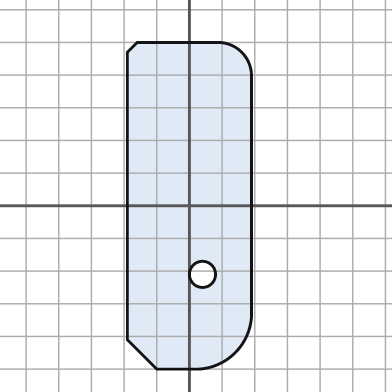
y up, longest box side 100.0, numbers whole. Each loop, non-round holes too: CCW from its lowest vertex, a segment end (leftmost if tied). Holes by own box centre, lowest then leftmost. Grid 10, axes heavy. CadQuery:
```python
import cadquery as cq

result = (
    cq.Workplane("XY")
    .moveTo(-10.0, -50.0)
    .lineTo(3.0, -50.0)
    .threePointArc((14.0, -45.0), (19.0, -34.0))
    .lineTo(19.0, 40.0)
    .threePointArc((16.0, 47.0), (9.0, 50.0))
    .lineTo(-16.0, 50.0)
    .lineTo(-19.0, 47.0)
    .lineTo(-19.0, -41.0)
    .close()
    .moveTo(4.0, -21.0)
    .circle(4.0)
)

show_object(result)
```